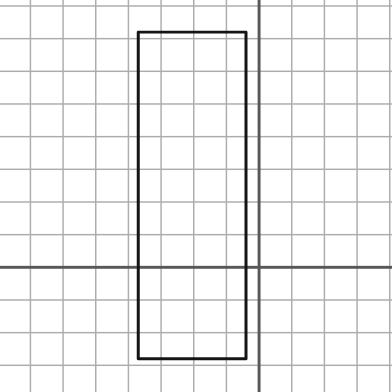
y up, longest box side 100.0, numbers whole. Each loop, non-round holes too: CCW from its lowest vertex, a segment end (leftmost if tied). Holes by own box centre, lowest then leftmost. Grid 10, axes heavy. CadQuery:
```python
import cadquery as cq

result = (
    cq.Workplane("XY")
    .moveTo(-37.0, -28.0)
    .lineTo(-4.0, -28.0)
    .lineTo(-4.0, 72.0)
    .lineTo(-37.0, 72.0)
    .close()
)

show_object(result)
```